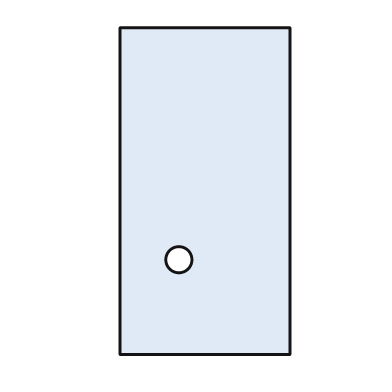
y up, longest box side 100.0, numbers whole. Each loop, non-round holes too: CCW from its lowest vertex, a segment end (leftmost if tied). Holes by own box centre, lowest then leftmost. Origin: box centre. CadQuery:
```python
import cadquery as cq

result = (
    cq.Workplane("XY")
    .moveTo(-26.0, -50.0)
    .lineTo(26.0, -50.0)
    .lineTo(26.0, 50.0)
    .lineTo(-26.0, 50.0)
    .close()
    .moveTo(-8.0, -21.0)
    .circle(4.0)
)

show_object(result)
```